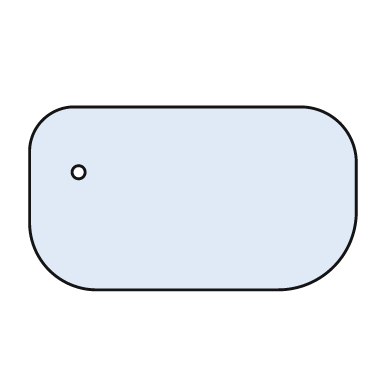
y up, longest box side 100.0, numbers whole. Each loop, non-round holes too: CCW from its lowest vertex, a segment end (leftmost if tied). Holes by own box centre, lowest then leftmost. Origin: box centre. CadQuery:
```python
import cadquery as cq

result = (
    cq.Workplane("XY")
    .moveTo(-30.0, -28.0)
    .lineTo(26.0, -28.0)
    .threePointArc((43.0, -21.0), (50.0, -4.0))
    .lineTo(50.0, 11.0)
    .threePointArc((45.0, 23.0), (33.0, 28.0))
    .lineTo(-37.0, 28.0)
    .threePointArc((-46.0, 24.0), (-50.0, 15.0))
    .lineTo(-50.0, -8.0)
    .threePointArc((-44.0, -22.0), (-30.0, -28.0))
    .close()
    .moveTo(-35.0, 8.0)
    .circle(2.0)
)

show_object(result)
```